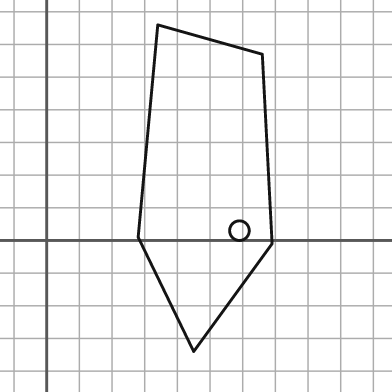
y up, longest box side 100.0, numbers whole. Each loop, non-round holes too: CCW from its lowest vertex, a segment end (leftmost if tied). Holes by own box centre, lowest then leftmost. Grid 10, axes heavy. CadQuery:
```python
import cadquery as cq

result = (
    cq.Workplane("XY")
    .moveTo(45.0, -34.0)
    .lineTo(69.0, -1.0)
    .lineTo(66.0, 57.0)
    .lineTo(34.0, 66.0)
    .lineTo(28.0, 1.0)
    .close()
    .moveTo(59.0, 3.0)
    .circle(3.0)
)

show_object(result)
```